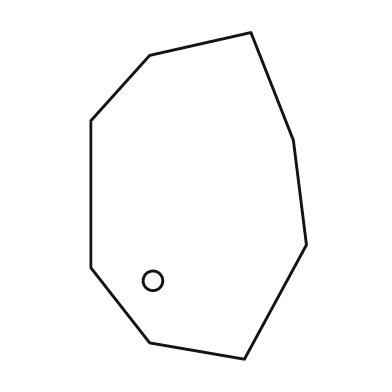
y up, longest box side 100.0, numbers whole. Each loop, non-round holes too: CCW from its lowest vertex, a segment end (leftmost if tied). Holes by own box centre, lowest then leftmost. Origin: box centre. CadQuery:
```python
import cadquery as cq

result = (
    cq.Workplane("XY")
    .moveTo(14.0, -50.0)
    .lineTo(33.0, -15.0)
    .lineTo(29.0, 17.0)
    .lineTo(16.0, 50.0)
    .lineTo(-15.0, 43.0)
    .lineTo(-33.0, 23.0)
    .lineTo(-33.0, -22.0)
    .lineTo(-15.0, -45.0)
    .close()
    .moveTo(-14.0, -26.0)
    .circle(3.0)
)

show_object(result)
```